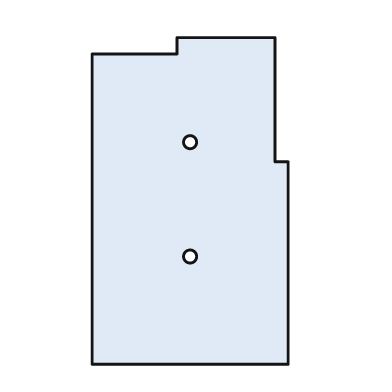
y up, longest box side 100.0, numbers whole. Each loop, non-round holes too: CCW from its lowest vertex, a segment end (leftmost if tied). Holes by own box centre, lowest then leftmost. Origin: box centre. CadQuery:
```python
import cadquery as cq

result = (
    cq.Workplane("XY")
    .moveTo(-30.0, -50.0)
    .lineTo(30.0, -50.0)
    .lineTo(30.0, 12.0)
    .lineTo(26.0, 12.0)
    .lineTo(26.0, 50.0)
    .lineTo(-4.0, 50.0)
    .lineTo(-4.0, 45.0)
    .lineTo(-30.0, 45.0)
    .close()
    .moveTo(0.0, -17.0)
    .circle(2.0)
    .moveTo(0.0, 18.0)
    .circle(2.0)
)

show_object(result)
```